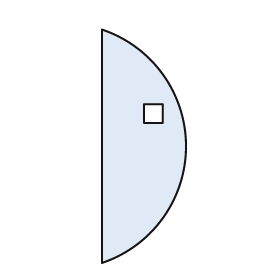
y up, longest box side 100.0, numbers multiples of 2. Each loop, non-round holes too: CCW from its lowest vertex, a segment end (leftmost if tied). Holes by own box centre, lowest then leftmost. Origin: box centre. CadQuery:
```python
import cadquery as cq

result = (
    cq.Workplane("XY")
    .moveTo(-18.0, -50.0)
    .threePointArc((18.0, 0.0), (-18.0, 50.0))
    .close()
    .moveTo(0.0, 10.0)
    .lineTo(8.0, 10.0)
    .lineTo(8.0, 18.0)
    .lineTo(0.0, 18.0)
    .close()
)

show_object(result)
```